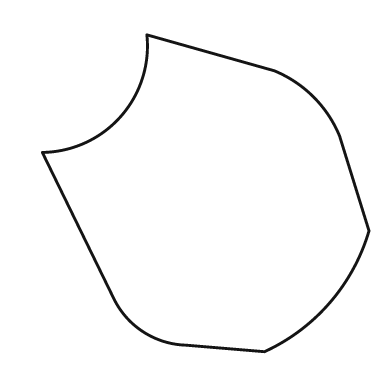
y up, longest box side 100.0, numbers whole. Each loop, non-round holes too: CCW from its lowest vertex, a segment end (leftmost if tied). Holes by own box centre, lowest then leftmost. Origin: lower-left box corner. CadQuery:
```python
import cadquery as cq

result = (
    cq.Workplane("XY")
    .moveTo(68.0, 0.0)
    .threePointArc((88.0, 15.0), (100.0, 37.0))
    .lineTo(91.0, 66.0)
    .threePointArc((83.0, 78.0), (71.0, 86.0))
    .lineTo(32.0, 97.0)
    .threePointArc((24.0, 72.0), (0.0, 61.0))
    .lineTo(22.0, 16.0)
    .threePointArc((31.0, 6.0), (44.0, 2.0))
    .close()
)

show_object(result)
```